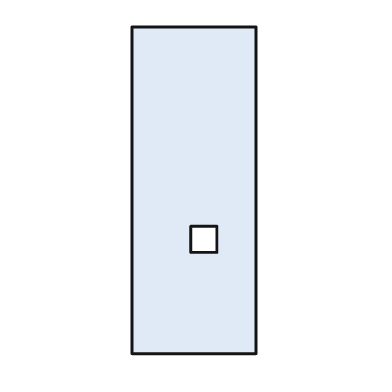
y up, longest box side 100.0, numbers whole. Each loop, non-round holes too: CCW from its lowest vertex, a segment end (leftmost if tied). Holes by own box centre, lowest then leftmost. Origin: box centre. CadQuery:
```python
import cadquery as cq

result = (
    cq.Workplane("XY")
    .moveTo(-19.0, -50.0)
    .lineTo(19.0, -50.0)
    .lineTo(19.0, 50.0)
    .lineTo(-19.0, 50.0)
    .close()
    .moveTo(-1.0, -19.0)
    .lineTo(7.0, -19.0)
    .lineTo(7.0, -11.0)
    .lineTo(-1.0, -11.0)
    .close()
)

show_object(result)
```